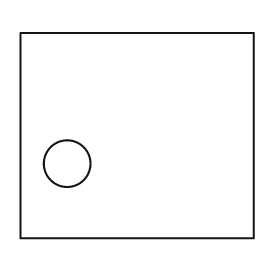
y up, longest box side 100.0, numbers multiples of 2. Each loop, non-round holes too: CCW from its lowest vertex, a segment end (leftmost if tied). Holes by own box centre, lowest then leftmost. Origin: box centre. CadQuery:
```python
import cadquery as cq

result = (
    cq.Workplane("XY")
    .moveTo(-50.0, -44.0)
    .lineTo(50.0, -44.0)
    .lineTo(50.0, 44.0)
    .lineTo(-50.0, 44.0)
    .close()
    .moveTo(-30.0, -12.0)
    .circle(10.0)
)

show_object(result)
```